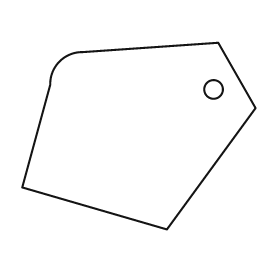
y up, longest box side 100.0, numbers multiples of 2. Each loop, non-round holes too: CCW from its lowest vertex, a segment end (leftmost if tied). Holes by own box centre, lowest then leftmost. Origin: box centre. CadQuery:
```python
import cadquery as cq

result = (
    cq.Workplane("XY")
    .moveTo(12.0, -40.0)
    .lineTo(50.0, 12.0)
    .lineTo(34.0, 40.0)
    .lineTo(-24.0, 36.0)
    .threePointArc((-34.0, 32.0), (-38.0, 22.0))
    .lineTo(-50.0, -22.0)
    .close()
    .moveTo(32.0, 20.0)
    .circle(4.0)
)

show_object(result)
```